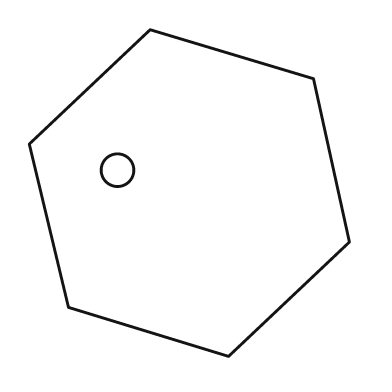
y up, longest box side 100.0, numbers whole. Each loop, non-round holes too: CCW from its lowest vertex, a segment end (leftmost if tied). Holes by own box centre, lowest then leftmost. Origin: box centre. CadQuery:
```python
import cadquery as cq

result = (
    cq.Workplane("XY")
    .moveTo(12.0, -50.0)
    .lineTo(49.0, -15.0)
    .lineTo(38.0, 35.0)
    .lineTo(-12.0, 50.0)
    .lineTo(-49.0, 15.0)
    .lineTo(-37.0, -35.0)
    .close()
    .moveTo(-22.0, 7.0)
    .circle(5.0)
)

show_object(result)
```